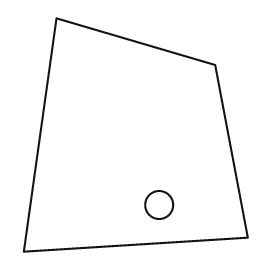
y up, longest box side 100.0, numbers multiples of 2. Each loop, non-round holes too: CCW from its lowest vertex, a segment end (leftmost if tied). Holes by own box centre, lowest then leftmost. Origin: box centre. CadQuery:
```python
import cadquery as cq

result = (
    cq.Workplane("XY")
    .moveTo(-48.0, -50.0)
    .lineTo(48.0, -44.0)
    .lineTo(34.0, 30.0)
    .lineTo(-34.0, 50.0)
    .close()
    .moveTo(10.0, -30.0)
    .circle(6.0)
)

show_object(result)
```